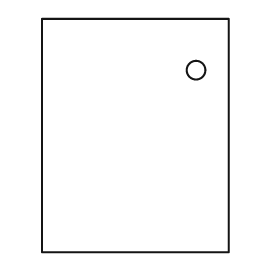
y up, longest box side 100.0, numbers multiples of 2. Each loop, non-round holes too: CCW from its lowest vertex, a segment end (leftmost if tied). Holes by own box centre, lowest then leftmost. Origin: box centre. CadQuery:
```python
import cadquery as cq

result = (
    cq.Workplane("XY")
    .moveTo(-40.0, -50.0)
    .lineTo(40.0, -50.0)
    .lineTo(40.0, 50.0)
    .lineTo(-40.0, 50.0)
    .close()
    .moveTo(26.0, 28.0)
    .circle(4.0)
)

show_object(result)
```